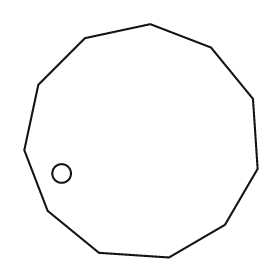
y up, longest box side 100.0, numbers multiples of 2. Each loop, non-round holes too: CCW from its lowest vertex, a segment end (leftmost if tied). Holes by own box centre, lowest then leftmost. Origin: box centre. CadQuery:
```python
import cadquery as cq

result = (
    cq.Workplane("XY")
    .moveTo(12.0, -50.0)
    .lineTo(36.0, -36.0)
    .lineTo(50.0, -12.0)
    .lineTo(48.0, 18.0)
    .lineTo(30.0, 40.0)
    .lineTo(4.0, 50.0)
    .lineTo(-24.0, 44.0)
    .lineTo(-44.0, 24.0)
    .lineTo(-50.0, -4.0)
    .lineTo(-40.0, -30.0)
    .lineTo(-18.0, -48.0)
    .close()
    .moveTo(-34.0, -14.0)
    .circle(4.0)
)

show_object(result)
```